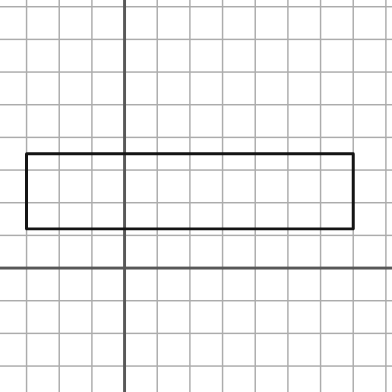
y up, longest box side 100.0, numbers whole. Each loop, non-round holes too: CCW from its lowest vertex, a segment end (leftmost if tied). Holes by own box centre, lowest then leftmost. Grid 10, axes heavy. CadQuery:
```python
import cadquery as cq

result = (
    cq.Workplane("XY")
    .moveTo(-30.0, 12.0)
    .lineTo(70.0, 12.0)
    .lineTo(70.0, 35.0)
    .lineTo(-30.0, 35.0)
    .close()
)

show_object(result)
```